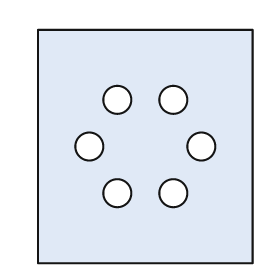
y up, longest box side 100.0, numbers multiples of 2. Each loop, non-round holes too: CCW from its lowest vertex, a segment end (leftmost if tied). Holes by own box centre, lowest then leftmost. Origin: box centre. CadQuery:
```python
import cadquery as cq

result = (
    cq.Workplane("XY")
    .moveTo(-46.0, -50.0)
    .lineTo(46.0, -50.0)
    .lineTo(46.0, 50.0)
    .lineTo(-46.0, 50.0)
    .close()
    .moveTo(-12.0, -20.0)
    .circle(6.0)
    .moveTo(12.0, -20.0)
    .circle(6.0)
    .moveTo(-24.0, 0.0)
    .circle(6.0)
    .moveTo(24.0, 0.0)
    .circle(6.0)
    .moveTo(-12.0, 20.0)
    .circle(6.0)
    .moveTo(12.0, 20.0)
    .circle(6.0)
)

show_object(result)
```